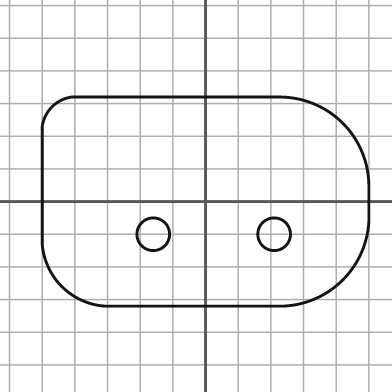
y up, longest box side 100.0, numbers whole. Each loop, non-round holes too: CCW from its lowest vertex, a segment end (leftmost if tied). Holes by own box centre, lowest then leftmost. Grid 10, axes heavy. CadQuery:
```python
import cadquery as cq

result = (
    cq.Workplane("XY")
    .moveTo(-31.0, -32.0)
    .lineTo(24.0, -32.0)
    .threePointArc((42.0, -24.0), (50.0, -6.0))
    .lineTo(50.0, 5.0)
    .threePointArc((42.0, 24.0), (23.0, 32.0))
    .lineTo(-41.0, 32.0)
    .threePointArc((-47.0, 29.0), (-50.0, 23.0))
    .lineTo(-50.0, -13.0)
    .threePointArc((-44.0, -26.0), (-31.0, -32.0))
    .close()
    .moveTo(-16.0, -10.0)
    .circle(5.0)
    .moveTo(21.0, -10.0)
    .circle(5.0)
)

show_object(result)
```